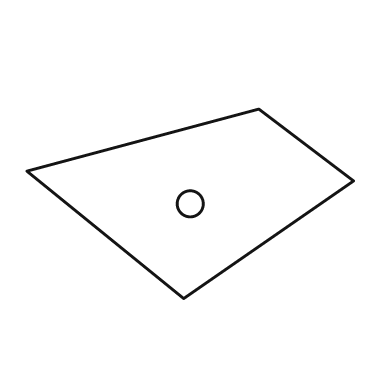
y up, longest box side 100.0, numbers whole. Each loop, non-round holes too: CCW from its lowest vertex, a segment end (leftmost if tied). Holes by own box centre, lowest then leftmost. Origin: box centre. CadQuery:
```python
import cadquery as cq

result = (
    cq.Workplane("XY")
    .moveTo(-2.0, -29.0)
    .lineTo(50.0, 7.0)
    .lineTo(21.0, 29.0)
    .lineTo(-50.0, 10.0)
    .close()
    .moveTo(0.0, 0.0)
    .circle(4.0)
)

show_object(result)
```